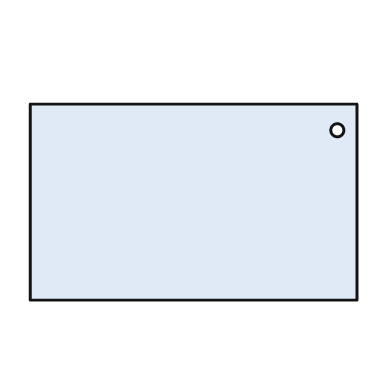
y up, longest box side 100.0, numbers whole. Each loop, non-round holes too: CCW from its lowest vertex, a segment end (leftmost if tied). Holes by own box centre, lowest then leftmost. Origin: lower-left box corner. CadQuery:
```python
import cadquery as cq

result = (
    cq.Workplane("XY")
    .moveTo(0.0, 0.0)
    .lineTo(100.0, 0.0)
    .lineTo(100.0, 60.0)
    .lineTo(0.0, 60.0)
    .close()
    .moveTo(94.0, 52.0)
    .circle(2.0)
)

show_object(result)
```